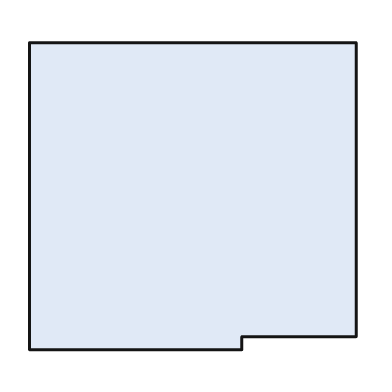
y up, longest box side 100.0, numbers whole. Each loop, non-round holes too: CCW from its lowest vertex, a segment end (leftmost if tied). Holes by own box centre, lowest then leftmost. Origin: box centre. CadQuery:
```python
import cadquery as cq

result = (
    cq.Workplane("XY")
    .moveTo(-50.0, -47.0)
    .lineTo(15.0, -47.0)
    .lineTo(15.0, -43.0)
    .lineTo(50.0, -43.0)
    .lineTo(50.0, 47.0)
    .lineTo(-50.0, 47.0)
    .close()
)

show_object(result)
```